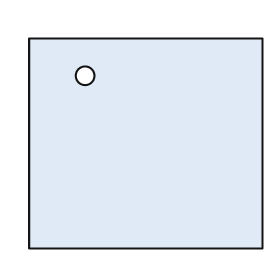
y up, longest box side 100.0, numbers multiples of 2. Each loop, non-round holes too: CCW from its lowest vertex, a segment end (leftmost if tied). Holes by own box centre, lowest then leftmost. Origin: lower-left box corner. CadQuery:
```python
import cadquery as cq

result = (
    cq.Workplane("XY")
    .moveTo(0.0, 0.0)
    .lineTo(100.0, 0.0)
    .lineTo(100.0, 90.0)
    .lineTo(0.0, 90.0)
    .close()
    .moveTo(24.0, 74.0)
    .circle(4.0)
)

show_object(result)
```